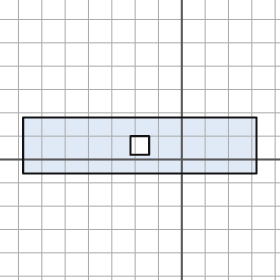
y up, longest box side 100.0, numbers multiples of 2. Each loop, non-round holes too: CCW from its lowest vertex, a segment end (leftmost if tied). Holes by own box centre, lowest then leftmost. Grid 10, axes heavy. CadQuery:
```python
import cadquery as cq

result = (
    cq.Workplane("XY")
    .moveTo(-68.0, -6.0)
    .lineTo(32.0, -6.0)
    .lineTo(32.0, 18.0)
    .lineTo(-68.0, 18.0)
    .close()
    .moveTo(-22.0, 2.0)
    .lineTo(-14.0, 2.0)
    .lineTo(-14.0, 10.0)
    .lineTo(-22.0, 10.0)
    .close()
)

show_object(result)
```